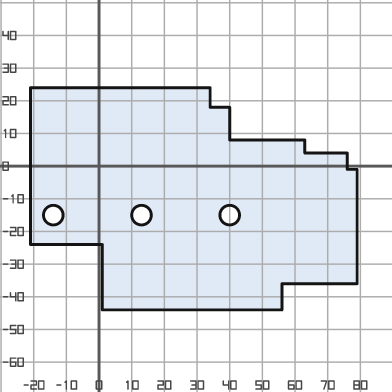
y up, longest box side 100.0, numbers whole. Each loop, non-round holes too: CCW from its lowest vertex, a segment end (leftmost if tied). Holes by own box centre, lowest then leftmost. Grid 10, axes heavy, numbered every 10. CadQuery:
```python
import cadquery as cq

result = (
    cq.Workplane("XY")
    .moveTo(1.0, -44.0)
    .lineTo(56.0, -44.0)
    .lineTo(56.0, -36.0)
    .lineTo(79.0, -36.0)
    .lineTo(79.0, -1.0)
    .lineTo(76.0, -1.0)
    .lineTo(76.0, 4.0)
    .lineTo(63.0, 4.0)
    .lineTo(63.0, 8.0)
    .lineTo(40.0, 8.0)
    .lineTo(40.0, 18.0)
    .lineTo(34.0, 18.0)
    .lineTo(34.0, 24.0)
    .lineTo(-21.0, 24.0)
    .lineTo(-21.0, -24.0)
    .lineTo(1.0, -24.0)
    .close()
    .moveTo(-14.0, -15.0)
    .circle(3.0)
    .moveTo(13.0, -15.0)
    .circle(3.0)
    .moveTo(40.0, -15.0)
    .circle(3.0)
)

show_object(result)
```